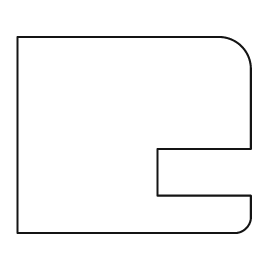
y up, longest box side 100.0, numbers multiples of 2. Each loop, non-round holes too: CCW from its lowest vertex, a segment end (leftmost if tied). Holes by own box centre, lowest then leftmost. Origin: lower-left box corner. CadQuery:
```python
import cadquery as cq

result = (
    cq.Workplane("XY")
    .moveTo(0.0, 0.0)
    .lineTo(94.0, 0.0)
    .threePointArc((98.0, 2.0), (100.0, 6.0))
    .lineTo(100.0, 16.0)
    .lineTo(60.0, 16.0)
    .lineTo(60.0, 36.0)
    .lineTo(100.0, 36.0)
    .lineTo(100.0, 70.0)
    .threePointArc((96.0, 80.0), (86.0, 84.0))
    .lineTo(0.0, 84.0)
    .close()
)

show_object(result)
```